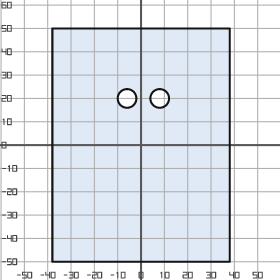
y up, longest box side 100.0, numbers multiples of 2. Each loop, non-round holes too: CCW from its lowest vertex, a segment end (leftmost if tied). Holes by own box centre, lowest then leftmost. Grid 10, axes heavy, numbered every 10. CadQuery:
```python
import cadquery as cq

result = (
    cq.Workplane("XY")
    .moveTo(-38.0, -50.0)
    .lineTo(38.0, -50.0)
    .lineTo(38.0, 50.0)
    .lineTo(-38.0, 50.0)
    .close()
    .moveTo(-6.0, 20.0)
    .circle(4.0)
    .moveTo(8.0, 20.0)
    .circle(4.0)
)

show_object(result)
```